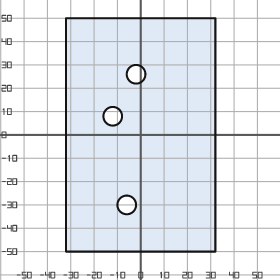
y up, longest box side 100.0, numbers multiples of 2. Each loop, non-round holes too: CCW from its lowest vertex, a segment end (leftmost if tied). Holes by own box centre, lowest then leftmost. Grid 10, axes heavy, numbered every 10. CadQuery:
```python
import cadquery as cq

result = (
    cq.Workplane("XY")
    .moveTo(-32.0, -50.0)
    .lineTo(32.0, -50.0)
    .lineTo(32.0, 50.0)
    .lineTo(-32.0, 50.0)
    .close()
    .moveTo(-6.0, -30.0)
    .circle(4.0)
    .moveTo(-12.0, 8.0)
    .circle(4.0)
    .moveTo(-2.0, 26.0)
    .circle(4.0)
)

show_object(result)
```